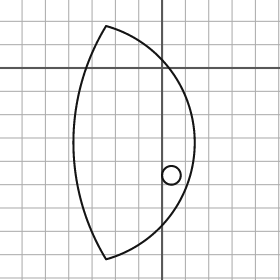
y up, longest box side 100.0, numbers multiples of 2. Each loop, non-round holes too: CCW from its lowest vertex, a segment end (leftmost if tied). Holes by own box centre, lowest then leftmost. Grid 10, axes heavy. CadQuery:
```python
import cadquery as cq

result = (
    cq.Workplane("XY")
    .moveTo(-24.0, -82.0)
    .threePointArc((14.0, -32.0), (-24.0, 18.0))
    .threePointArc((-38.0, -32.0), (-24.0, -82.0))
    .close()
    .moveTo(4.0, -46.0)
    .circle(4.0)
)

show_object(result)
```